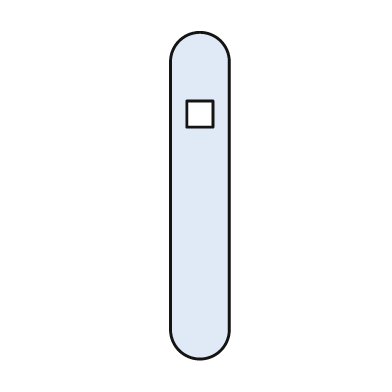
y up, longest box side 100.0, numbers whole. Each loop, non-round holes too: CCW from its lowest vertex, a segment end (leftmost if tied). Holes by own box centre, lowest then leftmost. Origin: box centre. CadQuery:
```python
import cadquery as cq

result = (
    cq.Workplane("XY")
    .moveTo(-9.0, -41.0)
    .threePointArc((0.0, -50.0), (9.0, -41.0))
    .lineTo(9.0, 41.0)
    .threePointArc((0.0, 50.0), (-9.0, 41.0))
    .close()
    .moveTo(-4.0, 21.0)
    .lineTo(4.0, 21.0)
    .lineTo(4.0, 29.0)
    .lineTo(-4.0, 29.0)
    .close()
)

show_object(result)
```